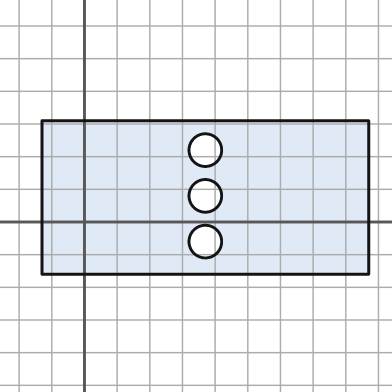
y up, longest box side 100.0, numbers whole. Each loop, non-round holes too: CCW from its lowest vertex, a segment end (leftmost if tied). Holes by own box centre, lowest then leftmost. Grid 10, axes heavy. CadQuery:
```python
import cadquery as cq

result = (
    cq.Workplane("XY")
    .moveTo(-13.0, -16.0)
    .lineTo(87.0, -16.0)
    .lineTo(87.0, 31.0)
    .lineTo(-13.0, 31.0)
    .close()
    .moveTo(37.0, -6.0)
    .circle(5.0)
    .moveTo(37.0, 8.0)
    .circle(5.0)
    .moveTo(37.0, 22.0)
    .circle(5.0)
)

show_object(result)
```